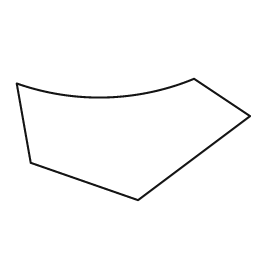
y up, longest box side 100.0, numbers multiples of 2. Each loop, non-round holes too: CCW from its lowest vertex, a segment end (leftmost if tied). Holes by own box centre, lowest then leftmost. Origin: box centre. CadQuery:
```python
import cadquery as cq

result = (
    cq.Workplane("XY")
    .moveTo(2.0, -26.0)
    .lineTo(50.0, 10.0)
    .lineTo(26.0, 26.0)
    .threePointArc((-12.0, 18.0), (-50.0, 24.0))
    .lineTo(-44.0, -10.0)
    .close()
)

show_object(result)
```